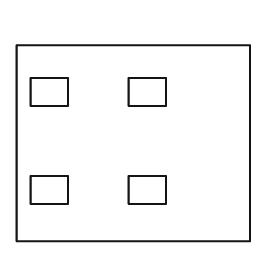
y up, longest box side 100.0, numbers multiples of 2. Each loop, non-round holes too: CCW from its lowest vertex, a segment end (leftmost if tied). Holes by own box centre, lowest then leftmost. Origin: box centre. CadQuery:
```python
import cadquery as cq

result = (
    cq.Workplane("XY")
    .moveTo(-50.0, -42.0)
    .lineTo(50.0, -42.0)
    .lineTo(50.0, 42.0)
    .lineTo(-50.0, 42.0)
    .close()
    .moveTo(-44.0, -26.0)
    .lineTo(-28.0, -26.0)
    .lineTo(-28.0, -14.0)
    .lineTo(-44.0, -14.0)
    .close()
    .moveTo(-2.0, -26.0)
    .lineTo(14.0, -26.0)
    .lineTo(14.0, -14.0)
    .lineTo(-2.0, -14.0)
    .close()
    .moveTo(-44.0, 16.0)
    .lineTo(-28.0, 16.0)
    .lineTo(-28.0, 28.0)
    .lineTo(-44.0, 28.0)
    .close()
    .moveTo(-2.0, 16.0)
    .lineTo(14.0, 16.0)
    .lineTo(14.0, 28.0)
    .lineTo(-2.0, 28.0)
    .close()
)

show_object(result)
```